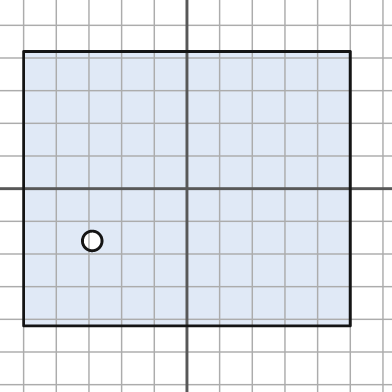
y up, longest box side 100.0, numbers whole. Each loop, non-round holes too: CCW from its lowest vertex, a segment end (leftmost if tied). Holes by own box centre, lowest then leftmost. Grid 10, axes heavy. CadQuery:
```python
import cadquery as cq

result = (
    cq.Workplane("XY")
    .moveTo(-50.0, -42.0)
    .lineTo(50.0, -42.0)
    .lineTo(50.0, 42.0)
    .lineTo(-50.0, 42.0)
    .close()
    .moveTo(-29.0, -16.0)
    .circle(3.0)
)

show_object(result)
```